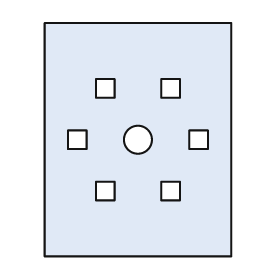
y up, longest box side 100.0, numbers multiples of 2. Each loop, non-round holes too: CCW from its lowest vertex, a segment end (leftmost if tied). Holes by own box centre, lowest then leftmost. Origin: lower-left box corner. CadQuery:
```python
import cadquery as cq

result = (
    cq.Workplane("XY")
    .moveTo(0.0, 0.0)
    .lineTo(80.0, 0.0)
    .lineTo(80.0, 100.0)
    .lineTo(0.0, 100.0)
    .close()
    .moveTo(22.0, 24.0)
    .lineTo(30.0, 24.0)
    .lineTo(30.0, 32.0)
    .lineTo(22.0, 32.0)
    .close()
    .moveTo(50.0, 24.0)
    .lineTo(58.0, 24.0)
    .lineTo(58.0, 32.0)
    .lineTo(50.0, 32.0)
    .close()
    .moveTo(10.0, 46.0)
    .lineTo(18.0, 46.0)
    .lineTo(18.0, 54.0)
    .lineTo(10.0, 54.0)
    .close()
    .moveTo(40.0, 50.0)
    .circle(6.0)
    .moveTo(62.0, 46.0)
    .lineTo(70.0, 46.0)
    .lineTo(70.0, 54.0)
    .lineTo(62.0, 54.0)
    .close()
    .moveTo(22.0, 68.0)
    .lineTo(30.0, 68.0)
    .lineTo(30.0, 76.0)
    .lineTo(22.0, 76.0)
    .close()
    .moveTo(50.0, 68.0)
    .lineTo(58.0, 68.0)
    .lineTo(58.0, 76.0)
    .lineTo(50.0, 76.0)
    .close()
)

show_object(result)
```